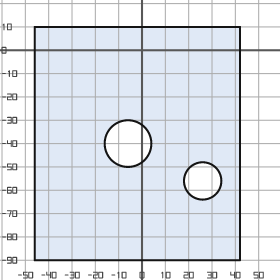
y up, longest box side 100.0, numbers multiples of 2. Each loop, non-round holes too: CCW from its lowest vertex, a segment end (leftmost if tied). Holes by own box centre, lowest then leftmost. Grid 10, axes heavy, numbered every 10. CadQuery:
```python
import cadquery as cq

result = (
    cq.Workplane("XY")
    .moveTo(-46.0, -90.0)
    .lineTo(42.0, -90.0)
    .lineTo(42.0, 10.0)
    .lineTo(-46.0, 10.0)
    .close()
    .moveTo(26.0, -56.0)
    .circle(8.0)
    .moveTo(-6.0, -40.0)
    .circle(10.0)
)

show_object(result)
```